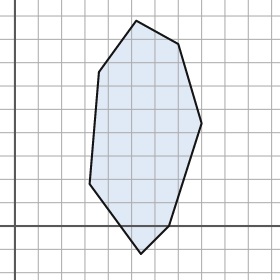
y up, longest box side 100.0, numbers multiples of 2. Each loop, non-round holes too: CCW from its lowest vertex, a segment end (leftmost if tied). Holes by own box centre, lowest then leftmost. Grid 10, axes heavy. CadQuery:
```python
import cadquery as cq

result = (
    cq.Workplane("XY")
    .moveTo(54.0, -12.0)
    .lineTo(66.0, 0.0)
    .lineTo(80.0, 44.0)
    .lineTo(70.0, 78.0)
    .lineTo(52.0, 88.0)
    .lineTo(36.0, 66.0)
    .lineTo(32.0, 18.0)
    .close()
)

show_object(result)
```